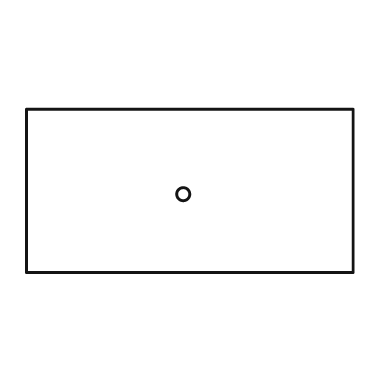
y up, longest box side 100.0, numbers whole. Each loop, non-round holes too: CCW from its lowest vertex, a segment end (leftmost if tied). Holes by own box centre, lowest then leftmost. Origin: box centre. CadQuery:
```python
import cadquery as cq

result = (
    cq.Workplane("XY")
    .moveTo(-50.0, -25.0)
    .lineTo(50.0, -25.0)
    .lineTo(50.0, 25.0)
    .lineTo(-50.0, 25.0)
    .close()
    .moveTo(-2.0, -1.0)
    .circle(2.0)
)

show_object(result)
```